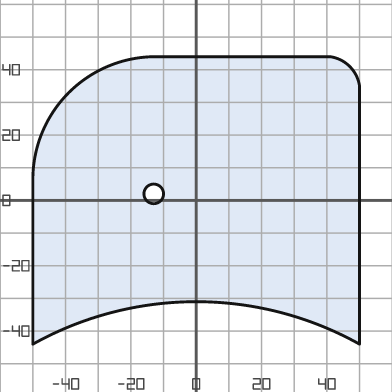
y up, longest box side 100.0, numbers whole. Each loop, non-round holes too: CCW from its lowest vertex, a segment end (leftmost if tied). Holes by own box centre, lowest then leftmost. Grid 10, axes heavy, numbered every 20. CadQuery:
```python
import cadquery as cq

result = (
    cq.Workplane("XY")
    .moveTo(-50.0, -44.0)
    .threePointArc((0.0, -31.0), (50.0, -44.0))
    .lineTo(50.0, 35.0)
    .threePointArc((47.0, 41.0), (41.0, 44.0))
    .lineTo(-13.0, 44.0)
    .threePointArc((-39.0, 33.0), (-50.0, 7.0))
    .close()
    .moveTo(-13.0, 2.0)
    .circle(3.0)
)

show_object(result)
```